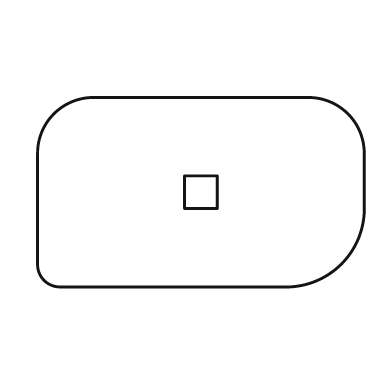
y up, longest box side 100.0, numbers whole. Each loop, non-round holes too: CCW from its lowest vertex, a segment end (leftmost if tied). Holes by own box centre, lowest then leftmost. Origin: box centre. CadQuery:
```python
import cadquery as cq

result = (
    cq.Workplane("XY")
    .moveTo(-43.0, -29.0)
    .lineTo(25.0, -29.0)
    .threePointArc((43.0, -22.0), (50.0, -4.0))
    .lineTo(50.0, 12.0)
    .threePointArc((45.0, 24.0), (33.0, 29.0))
    .lineTo(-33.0, 29.0)
    .threePointArc((-45.0, 24.0), (-50.0, 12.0))
    .lineTo(-50.0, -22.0)
    .threePointArc((-48.0, -27.0), (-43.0, -29.0))
    .close()
    .moveTo(-5.0, -5.0)
    .lineTo(5.0, -5.0)
    .lineTo(5.0, 5.0)
    .lineTo(-5.0, 5.0)
    .close()
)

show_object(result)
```